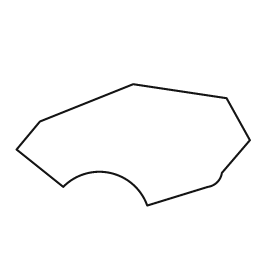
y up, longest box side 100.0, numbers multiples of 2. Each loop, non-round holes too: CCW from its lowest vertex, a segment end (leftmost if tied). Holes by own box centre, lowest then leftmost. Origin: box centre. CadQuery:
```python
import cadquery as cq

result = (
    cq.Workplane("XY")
    .moveTo(6.0, -26.0)
    .lineTo(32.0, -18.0)
    .threePointArc((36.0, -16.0), (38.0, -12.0))
    .lineTo(50.0, 2.0)
    .lineTo(40.0, 20.0)
    .lineTo(0.0, 26.0)
    .lineTo(-40.0, 10.0)
    .lineTo(-50.0, -2.0)
    .lineTo(-30.0, -18.0)
    .threePointArc((-10.0, -12.0), (6.0, -26.0))
    .close()
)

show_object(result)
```